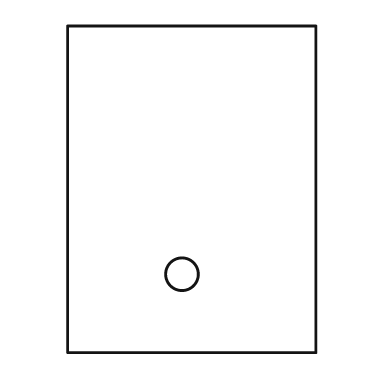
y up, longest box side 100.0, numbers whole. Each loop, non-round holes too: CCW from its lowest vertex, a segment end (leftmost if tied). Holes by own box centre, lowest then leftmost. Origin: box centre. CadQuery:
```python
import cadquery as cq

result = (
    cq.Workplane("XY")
    .moveTo(-38.0, -50.0)
    .lineTo(38.0, -50.0)
    .lineTo(38.0, 50.0)
    .lineTo(-38.0, 50.0)
    .close()
    .moveTo(-3.0, -26.0)
    .circle(5.0)
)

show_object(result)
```